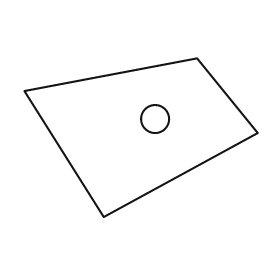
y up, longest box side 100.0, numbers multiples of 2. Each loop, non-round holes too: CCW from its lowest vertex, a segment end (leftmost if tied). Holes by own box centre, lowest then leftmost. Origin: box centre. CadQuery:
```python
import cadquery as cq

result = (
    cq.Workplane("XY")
    .moveTo(-16.0, -34.0)
    .lineTo(50.0, 2.0)
    .lineTo(24.0, 34.0)
    .lineTo(-50.0, 20.0)
    .close()
    .moveTo(6.0, 8.0)
    .circle(6.0)
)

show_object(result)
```